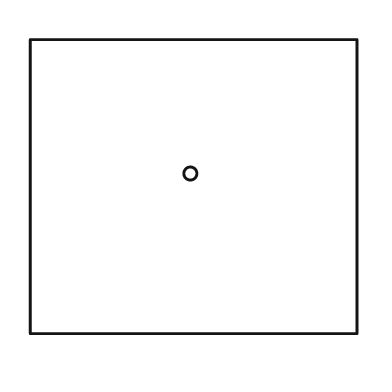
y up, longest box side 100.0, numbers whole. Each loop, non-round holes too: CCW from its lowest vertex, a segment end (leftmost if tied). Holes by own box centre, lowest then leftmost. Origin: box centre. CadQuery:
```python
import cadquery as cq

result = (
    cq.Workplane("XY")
    .moveTo(-50.0, -45.0)
    .lineTo(50.0, -45.0)
    .lineTo(50.0, 45.0)
    .lineTo(-50.0, 45.0)
    .close()
    .moveTo(-1.0, 4.0)
    .circle(2.0)
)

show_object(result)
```